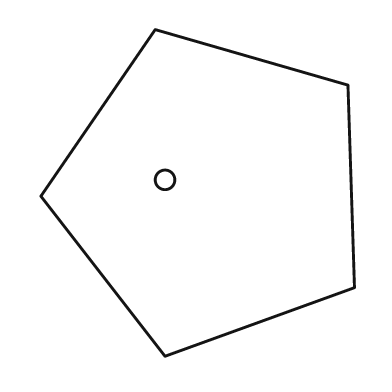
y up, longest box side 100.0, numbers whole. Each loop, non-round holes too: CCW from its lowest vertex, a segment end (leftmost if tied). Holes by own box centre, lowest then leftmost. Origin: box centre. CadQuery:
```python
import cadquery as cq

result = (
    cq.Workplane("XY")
    .moveTo(-10.0, -50.0)
    .lineTo(48.0, -29.0)
    .lineTo(46.0, 33.0)
    .lineTo(-13.0, 50.0)
    .lineTo(-48.0, -1.0)
    .close()
    .moveTo(-10.0, 4.0)
    .circle(3.0)
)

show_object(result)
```